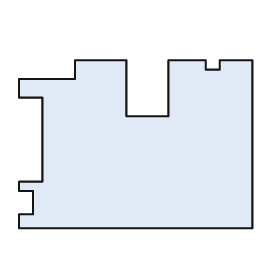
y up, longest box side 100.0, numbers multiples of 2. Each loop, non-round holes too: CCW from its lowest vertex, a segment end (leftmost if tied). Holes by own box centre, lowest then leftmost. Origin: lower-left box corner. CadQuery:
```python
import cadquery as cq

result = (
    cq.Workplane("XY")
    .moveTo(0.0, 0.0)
    .lineTo(100.0, 0.0)
    .lineTo(100.0, 72.0)
    .lineTo(86.0, 72.0)
    .lineTo(86.0, 68.0)
    .lineTo(80.0, 68.0)
    .lineTo(80.0, 72.0)
    .lineTo(64.0, 72.0)
    .lineTo(64.0, 48.0)
    .lineTo(46.0, 48.0)
    .lineTo(46.0, 72.0)
    .lineTo(24.0, 72.0)
    .lineTo(24.0, 64.0)
    .lineTo(0.0, 64.0)
    .lineTo(0.0, 56.0)
    .lineTo(10.0, 56.0)
    .lineTo(10.0, 20.0)
    .lineTo(0.0, 20.0)
    .lineTo(0.0, 16.0)
    .lineTo(6.0, 16.0)
    .lineTo(6.0, 6.0)
    .lineTo(0.0, 6.0)
    .close()
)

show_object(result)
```